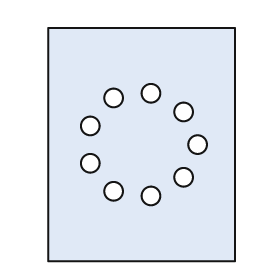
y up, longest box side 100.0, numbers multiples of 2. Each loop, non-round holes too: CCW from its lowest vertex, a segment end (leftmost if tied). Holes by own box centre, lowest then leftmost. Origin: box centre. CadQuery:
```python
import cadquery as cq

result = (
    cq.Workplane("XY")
    .moveTo(-40.0, -50.0)
    .lineTo(40.0, -50.0)
    .lineTo(40.0, 50.0)
    .lineTo(-40.0, 50.0)
    .close()
    .moveTo(4.0, -22.0)
    .circle(4.0)
    .moveTo(-12.0, -20.0)
    .circle(4.0)
    .moveTo(18.0, -14.0)
    .circle(4.0)
    .moveTo(-22.0, -8.0)
    .circle(4.0)
    .moveTo(24.0, 0.0)
    .circle(4.0)
    .moveTo(-22.0, 8.0)
    .circle(4.0)
    .moveTo(18.0, 14.0)
    .circle(4.0)
    .moveTo(-12.0, 20.0)
    .circle(4.0)
    .moveTo(4.0, 22.0)
    .circle(4.0)
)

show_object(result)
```